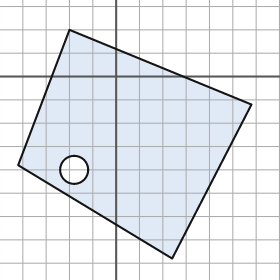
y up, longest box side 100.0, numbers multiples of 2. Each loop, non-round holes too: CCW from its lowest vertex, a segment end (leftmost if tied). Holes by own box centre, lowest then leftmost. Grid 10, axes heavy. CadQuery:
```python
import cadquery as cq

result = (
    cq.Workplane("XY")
    .moveTo(24.0, -78.0)
    .lineTo(58.0, -12.0)
    .lineTo(-20.0, 20.0)
    .lineTo(-42.0, -38.0)
    .close()
    .moveTo(-18.0, -40.0)
    .circle(6.0)
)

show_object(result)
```